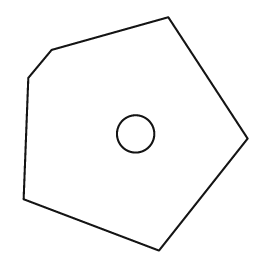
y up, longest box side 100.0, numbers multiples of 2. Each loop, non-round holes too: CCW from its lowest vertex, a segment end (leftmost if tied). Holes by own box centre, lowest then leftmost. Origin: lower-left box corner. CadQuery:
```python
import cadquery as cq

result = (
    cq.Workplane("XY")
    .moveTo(58.0, 0.0)
    .lineTo(96.0, 48.0)
    .lineTo(62.0, 100.0)
    .lineTo(12.0, 86.0)
    .lineTo(2.0, 74.0)
    .lineTo(0.0, 22.0)
    .close()
    .moveTo(48.0, 50.0)
    .circle(8.0)
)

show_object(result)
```